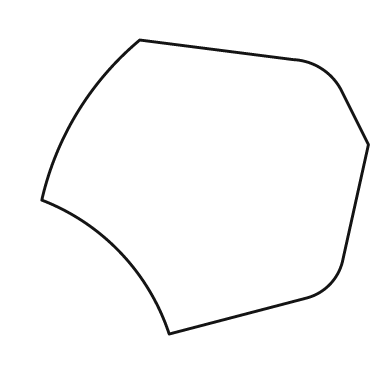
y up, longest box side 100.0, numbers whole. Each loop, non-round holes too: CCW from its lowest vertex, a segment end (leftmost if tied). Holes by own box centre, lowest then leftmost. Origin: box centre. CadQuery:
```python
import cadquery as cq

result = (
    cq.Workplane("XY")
    .moveTo(-11.0, -45.0)
    .lineTo(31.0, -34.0)
    .threePointArc((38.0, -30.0), (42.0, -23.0))
    .lineTo(50.0, 13.0)
    .lineTo(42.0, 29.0)
    .threePointArc((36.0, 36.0), (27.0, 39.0))
    .lineTo(-20.0, 45.0)
    .threePointArc((-39.0, 23.0), (-50.0, -4.0))
    .threePointArc((-26.0, -20.0), (-11.0, -45.0))
    .close()
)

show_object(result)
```